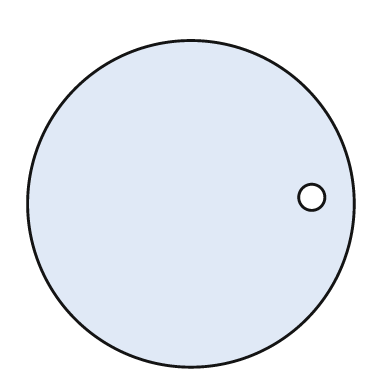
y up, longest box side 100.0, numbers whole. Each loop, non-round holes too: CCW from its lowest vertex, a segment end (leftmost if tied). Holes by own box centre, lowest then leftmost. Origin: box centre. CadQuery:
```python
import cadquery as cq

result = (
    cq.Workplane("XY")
    .moveTo(0.0, 0.0)
    .circle(50.0)
    .moveTo(37.0, 2.0)
    .circle(4.0)
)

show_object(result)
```